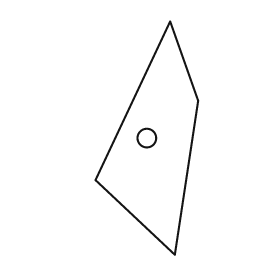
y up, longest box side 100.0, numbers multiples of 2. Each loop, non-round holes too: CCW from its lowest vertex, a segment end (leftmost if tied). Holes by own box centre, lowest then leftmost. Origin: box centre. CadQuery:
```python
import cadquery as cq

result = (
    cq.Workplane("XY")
    .moveTo(12.0, -50.0)
    .lineTo(22.0, 16.0)
    .lineTo(10.0, 50.0)
    .lineTo(-22.0, -18.0)
    .close()
    .moveTo(0.0, 0.0)
    .circle(4.0)
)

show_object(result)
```